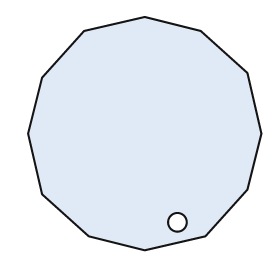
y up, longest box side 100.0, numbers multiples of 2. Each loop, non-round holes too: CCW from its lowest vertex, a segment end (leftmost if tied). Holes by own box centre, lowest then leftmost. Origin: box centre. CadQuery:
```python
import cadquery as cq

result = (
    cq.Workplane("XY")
    .moveTo(0.0, -50.0)
    .lineTo(26.0, -44.0)
    .lineTo(44.0, -24.0)
    .lineTo(50.0, 0.0)
    .lineTo(44.0, 26.0)
    .lineTo(24.0, 44.0)
    .lineTo(0.0, 50.0)
    .lineTo(-26.0, 44.0)
    .lineTo(-44.0, 24.0)
    .lineTo(-50.0, 0.0)
    .lineTo(-44.0, -26.0)
    .lineTo(-24.0, -44.0)
    .close()
    .moveTo(14.0, -38.0)
    .circle(4.0)
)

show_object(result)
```